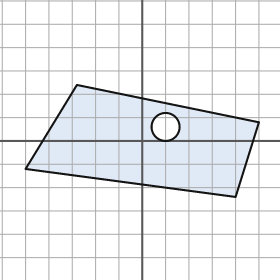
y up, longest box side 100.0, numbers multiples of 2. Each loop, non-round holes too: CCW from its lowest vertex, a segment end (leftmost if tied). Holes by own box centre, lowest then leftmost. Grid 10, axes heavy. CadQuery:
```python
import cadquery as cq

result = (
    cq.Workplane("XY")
    .moveTo(40.0, -24.0)
    .lineTo(50.0, 8.0)
    .lineTo(-28.0, 24.0)
    .lineTo(-50.0, -12.0)
    .close()
    .moveTo(10.0, 6.0)
    .circle(6.0)
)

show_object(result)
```